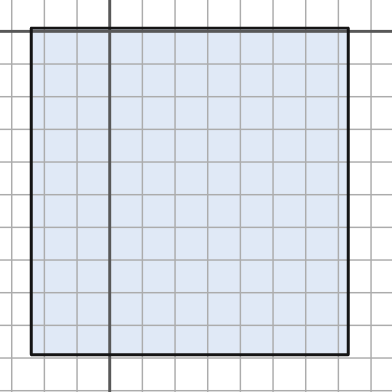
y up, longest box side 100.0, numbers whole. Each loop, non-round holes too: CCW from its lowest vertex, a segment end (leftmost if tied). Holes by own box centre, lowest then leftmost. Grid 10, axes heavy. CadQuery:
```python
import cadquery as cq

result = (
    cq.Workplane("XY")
    .moveTo(-24.0, -99.0)
    .lineTo(73.0, -99.0)
    .lineTo(73.0, 1.0)
    .lineTo(-24.0, 1.0)
    .close()
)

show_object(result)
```